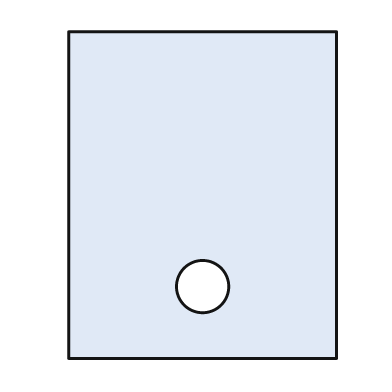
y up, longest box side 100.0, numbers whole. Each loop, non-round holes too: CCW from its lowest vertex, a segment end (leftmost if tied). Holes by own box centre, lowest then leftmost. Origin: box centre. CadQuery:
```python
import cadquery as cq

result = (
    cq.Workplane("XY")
    .moveTo(-41.0, -50.0)
    .lineTo(41.0, -50.0)
    .lineTo(41.0, 50.0)
    .lineTo(-41.0, 50.0)
    .close()
    .moveTo(0.0, -28.0)
    .circle(8.0)
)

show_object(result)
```